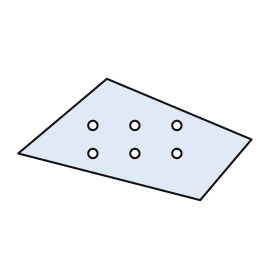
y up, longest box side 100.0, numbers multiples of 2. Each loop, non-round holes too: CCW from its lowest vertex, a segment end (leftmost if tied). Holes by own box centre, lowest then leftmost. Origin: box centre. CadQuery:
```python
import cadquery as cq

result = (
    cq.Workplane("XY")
    .moveTo(28.0, -26.0)
    .lineTo(50.0, 0.0)
    .lineTo(-12.0, 26.0)
    .lineTo(-50.0, -6.0)
    .close()
    .moveTo(-18.0, -6.0)
    .circle(2.0)
    .moveTo(0.0, -6.0)
    .circle(2.0)
    .moveTo(18.0, -6.0)
    .circle(2.0)
    .moveTo(-18.0, 6.0)
    .circle(2.0)
    .moveTo(0.0, 6.0)
    .circle(2.0)
    .moveTo(18.0, 6.0)
    .circle(2.0)
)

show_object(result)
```